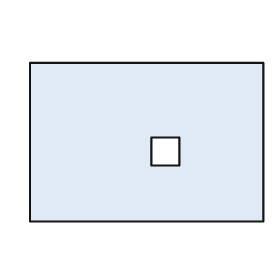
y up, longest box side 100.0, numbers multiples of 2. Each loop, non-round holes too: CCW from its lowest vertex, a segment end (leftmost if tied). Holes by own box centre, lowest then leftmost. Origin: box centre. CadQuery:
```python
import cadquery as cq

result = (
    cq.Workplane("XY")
    .moveTo(-50.0, -34.0)
    .lineTo(50.0, -34.0)
    .lineTo(50.0, 34.0)
    .lineTo(-50.0, 34.0)
    .close()
    .moveTo(2.0, -10.0)
    .lineTo(14.0, -10.0)
    .lineTo(14.0, 2.0)
    .lineTo(2.0, 2.0)
    .close()
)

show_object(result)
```